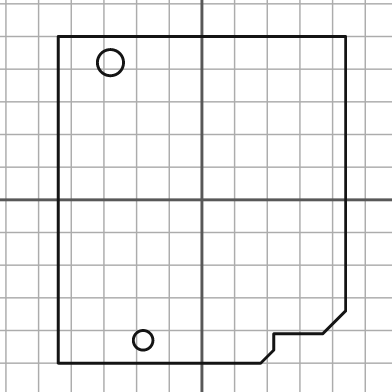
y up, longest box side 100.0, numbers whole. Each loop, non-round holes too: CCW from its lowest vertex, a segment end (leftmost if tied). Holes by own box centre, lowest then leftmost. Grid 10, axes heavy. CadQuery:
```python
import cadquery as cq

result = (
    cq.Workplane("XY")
    .moveTo(-44.0, -50.0)
    .lineTo(18.0, -50.0)
    .lineTo(22.0, -46.0)
    .lineTo(22.0, -41.0)
    .lineTo(37.0, -41.0)
    .lineTo(44.0, -34.0)
    .lineTo(44.0, 50.0)
    .lineTo(-44.0, 50.0)
    .close()
    .moveTo(-18.0, -43.0)
    .circle(3.0)
    .moveTo(-28.0, 42.0)
    .circle(4.0)
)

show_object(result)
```